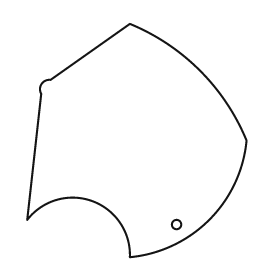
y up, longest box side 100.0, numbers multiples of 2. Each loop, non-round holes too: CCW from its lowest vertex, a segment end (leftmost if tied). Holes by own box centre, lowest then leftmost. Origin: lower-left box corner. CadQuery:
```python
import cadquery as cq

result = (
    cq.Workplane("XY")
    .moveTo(44.0, 0.0)
    .threePointArc((78.0, 16.0), (94.0, 50.0))
    .threePointArc((74.0, 80.0), (44.0, 100.0))
    .lineTo(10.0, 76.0)
    .threePointArc((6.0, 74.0), (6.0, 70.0))
    .lineTo(0.0, 16.0)
    .threePointArc((28.0, 24.0), (44.0, 0.0))
    .close()
    .moveTo(64.0, 14.0)
    .circle(2.0)
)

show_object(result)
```